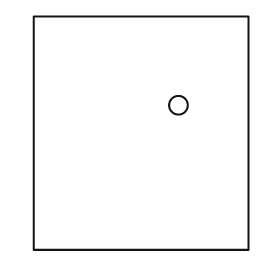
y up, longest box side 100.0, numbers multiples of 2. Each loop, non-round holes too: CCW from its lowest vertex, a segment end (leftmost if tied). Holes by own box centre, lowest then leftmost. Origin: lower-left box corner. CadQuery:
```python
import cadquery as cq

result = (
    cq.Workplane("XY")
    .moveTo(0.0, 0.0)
    .lineTo(92.0, 0.0)
    .lineTo(92.0, 100.0)
    .lineTo(0.0, 100.0)
    .close()
    .moveTo(62.0, 62.0)
    .circle(4.0)
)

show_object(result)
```